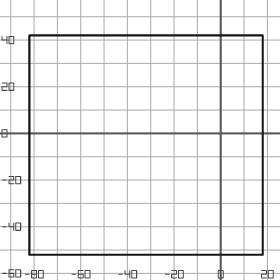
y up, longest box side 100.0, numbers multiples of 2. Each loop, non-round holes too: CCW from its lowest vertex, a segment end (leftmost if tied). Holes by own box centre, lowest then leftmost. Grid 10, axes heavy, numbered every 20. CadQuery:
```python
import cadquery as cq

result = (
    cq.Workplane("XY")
    .moveTo(-82.0, -52.0)
    .lineTo(18.0, -52.0)
    .lineTo(18.0, 42.0)
    .lineTo(-82.0, 42.0)
    .close()
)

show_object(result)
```